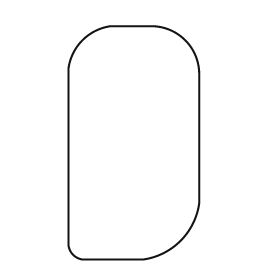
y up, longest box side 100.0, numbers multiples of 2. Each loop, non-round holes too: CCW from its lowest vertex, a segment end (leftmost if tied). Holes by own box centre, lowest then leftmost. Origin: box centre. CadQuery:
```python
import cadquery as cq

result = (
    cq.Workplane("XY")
    .moveTo(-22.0, -50.0)
    .lineTo(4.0, -50.0)
    .threePointArc((20.0, -42.0), (28.0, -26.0))
    .lineTo(28.0, 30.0)
    .threePointArc((22.0, 44.0), (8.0, 50.0))
    .lineTo(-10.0, 50.0)
    .threePointArc((-22.0, 44.0), (-28.0, 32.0))
    .lineTo(-28.0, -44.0)
    .threePointArc((-26.0, -48.0), (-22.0, -50.0))
    .close()
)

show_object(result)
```